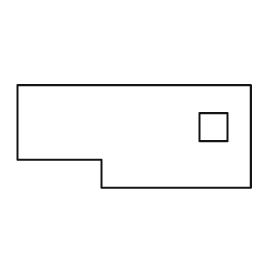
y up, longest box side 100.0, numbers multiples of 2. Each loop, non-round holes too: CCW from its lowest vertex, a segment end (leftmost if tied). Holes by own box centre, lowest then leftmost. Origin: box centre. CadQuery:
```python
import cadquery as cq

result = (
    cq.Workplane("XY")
    .moveTo(-14.0, -22.0)
    .lineTo(50.0, -22.0)
    .lineTo(50.0, 22.0)
    .lineTo(-50.0, 22.0)
    .lineTo(-50.0, -10.0)
    .lineTo(-14.0, -10.0)
    .close()
    .moveTo(28.0, -2.0)
    .lineTo(40.0, -2.0)
    .lineTo(40.0, 10.0)
    .lineTo(28.0, 10.0)
    .close()
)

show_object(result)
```